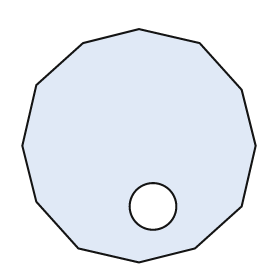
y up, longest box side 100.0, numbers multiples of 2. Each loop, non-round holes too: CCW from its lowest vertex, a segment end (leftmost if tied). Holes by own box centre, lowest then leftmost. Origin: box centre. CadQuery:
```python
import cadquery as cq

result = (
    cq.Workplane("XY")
    .moveTo(0.0, -50.0)
    .lineTo(24.0, -44.0)
    .lineTo(44.0, -26.0)
    .lineTo(50.0, 0.0)
    .lineTo(44.0, 24.0)
    .lineTo(26.0, 44.0)
    .lineTo(0.0, 50.0)
    .lineTo(-24.0, 44.0)
    .lineTo(-44.0, 26.0)
    .lineTo(-50.0, 0.0)
    .lineTo(-44.0, -24.0)
    .lineTo(-26.0, -44.0)
    .close()
    .moveTo(6.0, -26.0)
    .circle(10.0)
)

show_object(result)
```